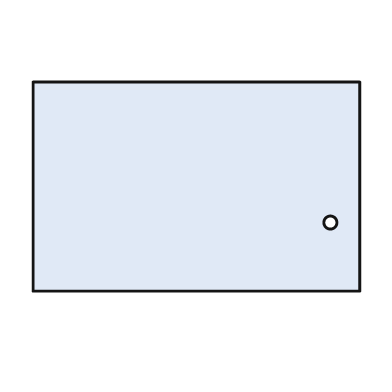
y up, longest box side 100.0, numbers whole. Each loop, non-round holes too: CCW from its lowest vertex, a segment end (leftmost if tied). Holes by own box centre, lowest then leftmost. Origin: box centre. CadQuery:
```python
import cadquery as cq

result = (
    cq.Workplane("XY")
    .moveTo(-50.0, -32.0)
    .lineTo(50.0, -32.0)
    .lineTo(50.0, 32.0)
    .lineTo(-50.0, 32.0)
    .close()
    .moveTo(41.0, -11.0)
    .circle(2.0)
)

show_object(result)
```